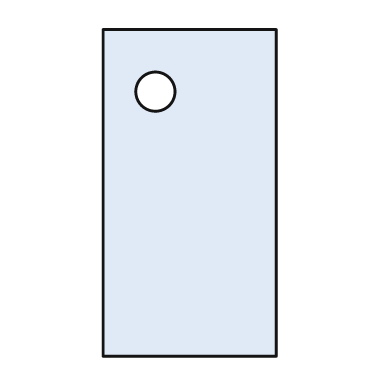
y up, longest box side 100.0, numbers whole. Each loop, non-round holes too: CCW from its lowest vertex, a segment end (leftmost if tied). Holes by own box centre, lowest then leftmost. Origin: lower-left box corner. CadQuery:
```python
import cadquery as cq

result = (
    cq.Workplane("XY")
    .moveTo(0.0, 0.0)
    .lineTo(53.0, 0.0)
    .lineTo(53.0, 100.0)
    .lineTo(0.0, 100.0)
    .close()
    .moveTo(16.0, 81.0)
    .circle(6.0)
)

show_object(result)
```